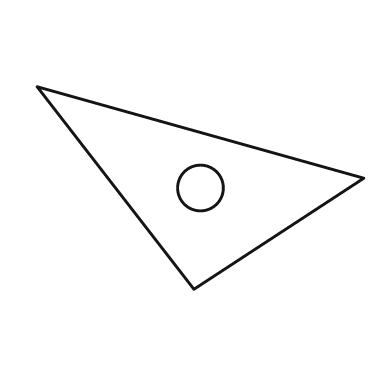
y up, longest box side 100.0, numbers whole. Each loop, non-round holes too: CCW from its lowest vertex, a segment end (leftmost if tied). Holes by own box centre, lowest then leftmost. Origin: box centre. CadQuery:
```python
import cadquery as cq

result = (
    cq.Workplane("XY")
    .moveTo(-2.0, -31.0)
    .lineTo(50.0, 3.0)
    .lineTo(-50.0, 31.0)
    .close()
    .moveTo(0.0, 0.0)
    .circle(7.0)
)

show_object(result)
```